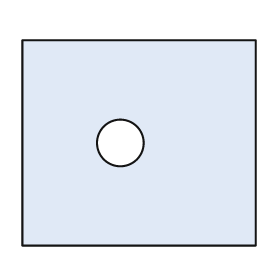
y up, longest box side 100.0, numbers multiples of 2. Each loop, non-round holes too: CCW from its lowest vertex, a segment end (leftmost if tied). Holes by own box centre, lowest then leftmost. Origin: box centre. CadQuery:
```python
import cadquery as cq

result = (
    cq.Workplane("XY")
    .moveTo(-50.0, -44.0)
    .lineTo(50.0, -44.0)
    .lineTo(50.0, 44.0)
    .lineTo(-50.0, 44.0)
    .close()
    .moveTo(-8.0, 0.0)
    .circle(10.0)
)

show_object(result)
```